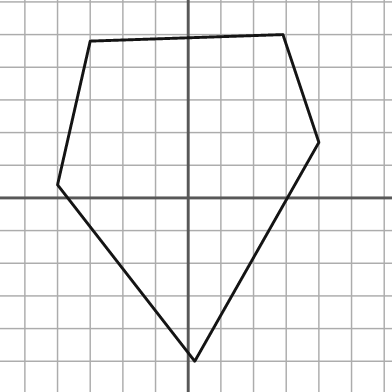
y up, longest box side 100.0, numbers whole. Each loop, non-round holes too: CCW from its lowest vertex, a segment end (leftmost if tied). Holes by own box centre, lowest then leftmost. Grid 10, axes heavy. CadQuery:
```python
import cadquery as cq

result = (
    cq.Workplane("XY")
    .moveTo(2.0, -50.0)
    .lineTo(40.0, 17.0)
    .lineTo(29.0, 50.0)
    .lineTo(-30.0, 48.0)
    .lineTo(-40.0, 4.0)
    .close()
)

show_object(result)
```